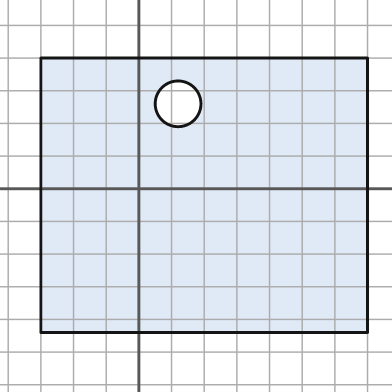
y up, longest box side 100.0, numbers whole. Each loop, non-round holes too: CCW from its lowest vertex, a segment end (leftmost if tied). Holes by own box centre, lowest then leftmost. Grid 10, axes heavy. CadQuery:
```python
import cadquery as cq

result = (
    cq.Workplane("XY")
    .moveTo(-30.0, -44.0)
    .lineTo(70.0, -44.0)
    .lineTo(70.0, 40.0)
    .lineTo(-30.0, 40.0)
    .close()
    .moveTo(12.0, 26.0)
    .circle(7.0)
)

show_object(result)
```